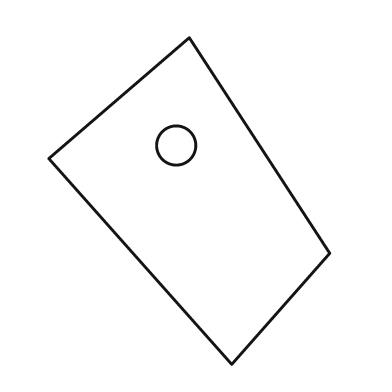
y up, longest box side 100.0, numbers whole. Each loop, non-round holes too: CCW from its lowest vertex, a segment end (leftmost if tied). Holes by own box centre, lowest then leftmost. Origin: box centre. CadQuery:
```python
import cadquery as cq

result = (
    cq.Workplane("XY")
    .moveTo(13.0, -50.0)
    .lineTo(43.0, -16.0)
    .lineTo(0.0, 50.0)
    .lineTo(-43.0, 13.0)
    .close()
    .moveTo(-4.0, 17.0)
    .circle(6.0)
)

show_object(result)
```